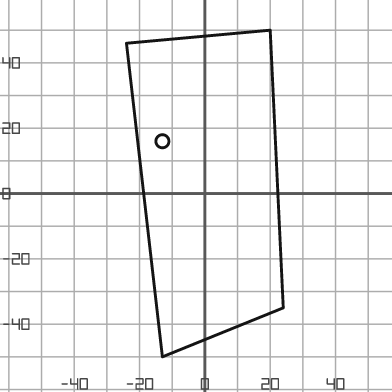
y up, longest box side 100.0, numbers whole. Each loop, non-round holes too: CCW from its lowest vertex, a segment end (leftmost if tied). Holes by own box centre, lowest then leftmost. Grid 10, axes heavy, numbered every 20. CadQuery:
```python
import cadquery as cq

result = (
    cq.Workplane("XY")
    .moveTo(-13.0, -50.0)
    .lineTo(24.0, -35.0)
    .lineTo(20.0, 50.0)
    .lineTo(-24.0, 46.0)
    .close()
    .moveTo(-13.0, 16.0)
    .circle(2.0)
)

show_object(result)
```